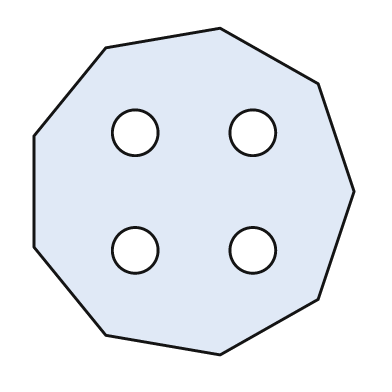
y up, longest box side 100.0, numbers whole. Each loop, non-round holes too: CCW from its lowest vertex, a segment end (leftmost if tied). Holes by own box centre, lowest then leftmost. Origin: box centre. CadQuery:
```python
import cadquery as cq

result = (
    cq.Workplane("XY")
    .moveTo(8.0, -50.0)
    .lineTo(38.0, -33.0)
    .lineTo(49.0, 0.0)
    .lineTo(38.0, 33.0)
    .lineTo(8.0, 50.0)
    .lineTo(-27.0, 44.0)
    .lineTo(-49.0, 17.0)
    .lineTo(-49.0, -17.0)
    .lineTo(-27.0, -44.0)
    .close()
    .moveTo(-18.0, -18.0)
    .circle(7.0)
    .moveTo(18.0, -18.0)
    .circle(7.0)
    .moveTo(-18.0, 18.0)
    .circle(7.0)
    .moveTo(18.0, 18.0)
    .circle(7.0)
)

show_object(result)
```